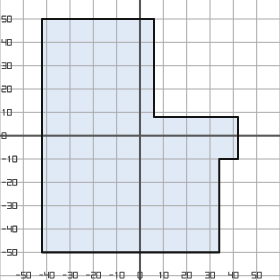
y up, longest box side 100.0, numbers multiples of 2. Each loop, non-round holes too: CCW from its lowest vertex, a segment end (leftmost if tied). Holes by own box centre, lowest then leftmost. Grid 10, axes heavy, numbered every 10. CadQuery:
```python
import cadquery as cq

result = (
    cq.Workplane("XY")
    .moveTo(-42.0, -50.0)
    .lineTo(34.0, -50.0)
    .lineTo(34.0, -10.0)
    .lineTo(42.0, -10.0)
    .lineTo(42.0, 8.0)
    .lineTo(6.0, 8.0)
    .lineTo(6.0, 50.0)
    .lineTo(-42.0, 50.0)
    .close()
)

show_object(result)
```